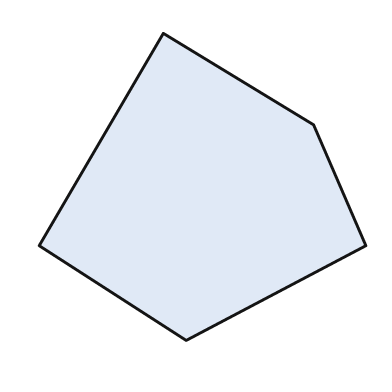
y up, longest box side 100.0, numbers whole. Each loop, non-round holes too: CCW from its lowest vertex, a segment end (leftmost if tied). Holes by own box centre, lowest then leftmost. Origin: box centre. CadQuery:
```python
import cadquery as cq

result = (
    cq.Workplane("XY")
    .moveTo(-5.0, -47.0)
    .lineTo(50.0, -18.0)
    .lineTo(34.0, 19.0)
    .lineTo(-12.0, 47.0)
    .lineTo(-50.0, -18.0)
    .close()
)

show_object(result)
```